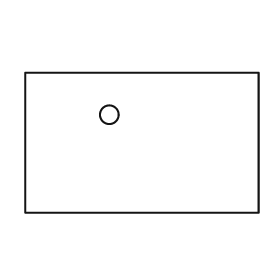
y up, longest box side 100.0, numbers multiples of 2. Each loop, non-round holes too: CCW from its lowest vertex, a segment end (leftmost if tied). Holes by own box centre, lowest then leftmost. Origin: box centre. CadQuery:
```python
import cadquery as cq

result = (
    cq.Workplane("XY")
    .moveTo(-50.0, -30.0)
    .lineTo(50.0, -30.0)
    .lineTo(50.0, 30.0)
    .lineTo(-50.0, 30.0)
    .close()
    .moveTo(-14.0, 12.0)
    .circle(4.0)
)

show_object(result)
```